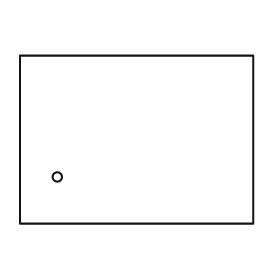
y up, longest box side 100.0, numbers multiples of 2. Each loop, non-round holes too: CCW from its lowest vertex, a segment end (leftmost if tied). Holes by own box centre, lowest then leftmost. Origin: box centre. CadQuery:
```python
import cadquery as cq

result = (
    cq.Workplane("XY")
    .moveTo(-50.0, -36.0)
    .lineTo(50.0, -36.0)
    .lineTo(50.0, 36.0)
    .lineTo(-50.0, 36.0)
    .close()
    .moveTo(-34.0, -16.0)
    .circle(2.0)
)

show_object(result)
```